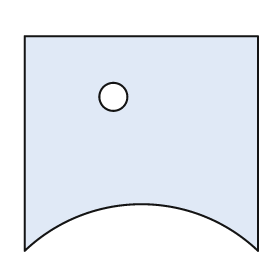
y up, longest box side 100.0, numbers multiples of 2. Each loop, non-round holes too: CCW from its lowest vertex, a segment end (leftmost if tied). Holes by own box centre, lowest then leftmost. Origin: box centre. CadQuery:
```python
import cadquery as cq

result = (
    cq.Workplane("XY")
    .moveTo(-50.0, -46.0)
    .threePointArc((0.0, -26.0), (50.0, -46.0))
    .lineTo(50.0, 46.0)
    .lineTo(-50.0, 46.0)
    .close()
    .moveTo(-12.0, 20.0)
    .circle(6.0)
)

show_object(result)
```